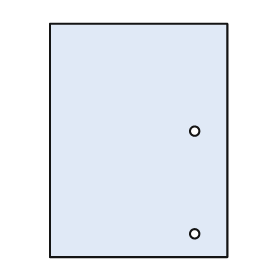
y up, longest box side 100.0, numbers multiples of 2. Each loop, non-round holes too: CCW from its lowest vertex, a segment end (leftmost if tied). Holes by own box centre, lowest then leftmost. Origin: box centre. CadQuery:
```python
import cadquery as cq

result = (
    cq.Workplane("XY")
    .moveTo(-38.0, -50.0)
    .lineTo(38.0, -50.0)
    .lineTo(38.0, 50.0)
    .lineTo(-38.0, 50.0)
    .close()
    .moveTo(24.0, -40.0)
    .circle(2.0)
    .moveTo(24.0, 4.0)
    .circle(2.0)
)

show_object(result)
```